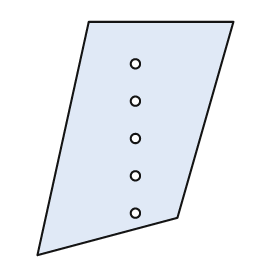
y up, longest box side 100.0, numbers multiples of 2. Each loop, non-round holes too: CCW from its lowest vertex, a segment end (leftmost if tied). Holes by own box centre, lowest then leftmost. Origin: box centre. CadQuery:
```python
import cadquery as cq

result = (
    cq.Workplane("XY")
    .moveTo(-42.0, -50.0)
    .lineTo(18.0, -34.0)
    .lineTo(42.0, 50.0)
    .lineTo(-20.0, 50.0)
    .close()
    .moveTo(0.0, -32.0)
    .circle(2.0)
    .moveTo(0.0, -16.0)
    .circle(2.0)
    .moveTo(0.0, 0.0)
    .circle(2.0)
    .moveTo(0.0, 16.0)
    .circle(2.0)
    .moveTo(0.0, 32.0)
    .circle(2.0)
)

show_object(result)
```